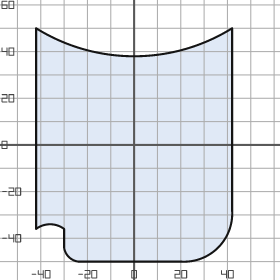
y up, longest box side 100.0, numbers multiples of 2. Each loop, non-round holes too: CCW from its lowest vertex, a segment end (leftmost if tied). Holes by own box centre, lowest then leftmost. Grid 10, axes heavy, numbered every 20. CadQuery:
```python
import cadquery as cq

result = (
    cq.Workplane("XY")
    .moveTo(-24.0, -50.0)
    .lineTo(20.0, -50.0)
    .threePointArc((36.0, -44.0), (42.0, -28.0))
    .lineTo(42.0, 50.0)
    .threePointArc((0.0, 38.0), (-42.0, 50.0))
    .lineTo(-42.0, -36.0)
    .threePointArc((-36.0, -34.0), (-30.0, -36.0))
    .lineTo(-30.0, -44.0)
    .threePointArc((-28.0, -48.0), (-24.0, -50.0))
    .close()
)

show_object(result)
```